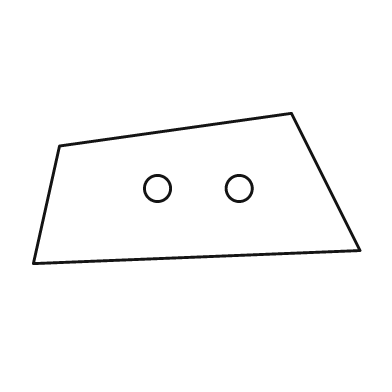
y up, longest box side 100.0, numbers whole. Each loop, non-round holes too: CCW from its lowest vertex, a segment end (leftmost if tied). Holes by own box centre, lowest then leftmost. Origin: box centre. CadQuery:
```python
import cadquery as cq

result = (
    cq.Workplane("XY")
    .moveTo(-50.0, -23.0)
    .lineTo(50.0, -19.0)
    .lineTo(29.0, 23.0)
    .lineTo(-42.0, 13.0)
    .close()
    .moveTo(-12.0, 0.0)
    .circle(4.0)
    .moveTo(13.0, 0.0)
    .circle(4.0)
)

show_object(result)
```